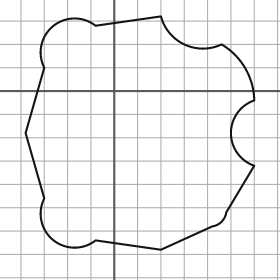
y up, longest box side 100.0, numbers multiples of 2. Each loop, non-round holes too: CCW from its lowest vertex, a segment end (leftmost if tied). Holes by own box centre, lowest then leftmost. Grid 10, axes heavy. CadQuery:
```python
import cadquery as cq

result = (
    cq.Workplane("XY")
    .moveTo(20.0, -68.0)
    .lineTo(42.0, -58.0)
    .threePointArc((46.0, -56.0), (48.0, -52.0))
    .lineTo(60.0, -32.0)
    .threePointArc((50.0, -18.0), (60.0, -4.0))
    .threePointArc((56.0, 10.0), (46.0, 20.0))
    .threePointArc((30.0, 20.0), (20.0, 32.0))
    .lineTo(-8.0, 28.0)
    .threePointArc((-26.0, 28.0), (-30.0, 10.0))
    .lineTo(-38.0, -18.0)
    .lineTo(-30.0, -46.0)
    .threePointArc((-26.0, -64.0), (-8.0, -64.0))
    .close()
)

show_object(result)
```